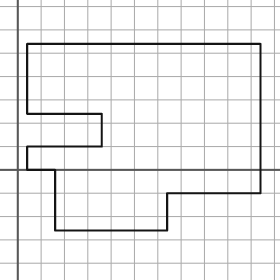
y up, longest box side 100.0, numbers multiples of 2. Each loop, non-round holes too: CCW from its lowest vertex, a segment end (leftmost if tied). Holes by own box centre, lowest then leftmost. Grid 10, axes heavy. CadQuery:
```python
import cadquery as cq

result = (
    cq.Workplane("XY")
    .moveTo(16.0, -26.0)
    .lineTo(64.0, -26.0)
    .lineTo(64.0, -10.0)
    .lineTo(104.0, -10.0)
    .lineTo(104.0, 54.0)
    .lineTo(4.0, 54.0)
    .lineTo(4.0, 24.0)
    .lineTo(36.0, 24.0)
    .lineTo(36.0, 10.0)
    .lineTo(4.0, 10.0)
    .lineTo(4.0, 0.0)
    .lineTo(16.0, 0.0)
    .close()
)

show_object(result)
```